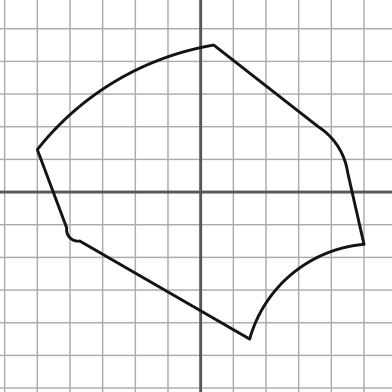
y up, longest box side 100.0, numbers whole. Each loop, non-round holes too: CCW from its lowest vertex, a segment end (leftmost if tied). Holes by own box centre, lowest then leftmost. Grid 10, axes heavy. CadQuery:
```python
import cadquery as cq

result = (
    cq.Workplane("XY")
    .moveTo(15.0, -45.0)
    .threePointArc((28.0, -25.0), (50.0, -16.0))
    .lineTo(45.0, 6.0)
    .threePointArc((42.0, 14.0), (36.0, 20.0))
    .lineTo(4.0, 45.0)
    .threePointArc((-26.0, 34.0), (-50.0, 13.0))
    .lineTo(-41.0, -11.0)
    .threePointArc((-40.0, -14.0), (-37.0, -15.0))
    .close()
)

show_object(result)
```